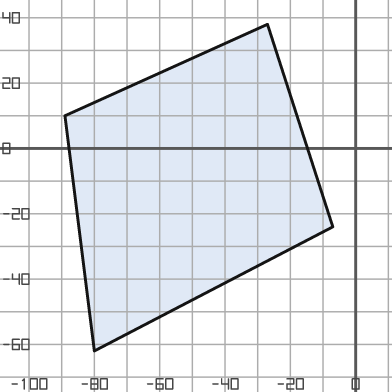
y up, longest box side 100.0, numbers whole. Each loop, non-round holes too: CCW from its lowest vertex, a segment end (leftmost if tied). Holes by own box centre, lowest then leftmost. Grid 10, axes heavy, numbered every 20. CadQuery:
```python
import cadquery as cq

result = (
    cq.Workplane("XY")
    .moveTo(-80.0, -62.0)
    .lineTo(-7.0, -24.0)
    .lineTo(-27.0, 38.0)
    .lineTo(-89.0, 10.0)
    .close()
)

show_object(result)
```